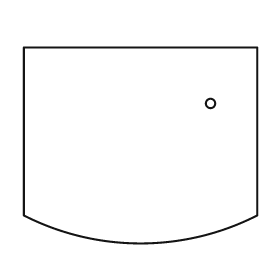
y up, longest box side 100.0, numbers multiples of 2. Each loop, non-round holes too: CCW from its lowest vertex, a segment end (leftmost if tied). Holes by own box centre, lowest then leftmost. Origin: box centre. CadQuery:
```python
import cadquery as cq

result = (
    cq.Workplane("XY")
    .moveTo(-50.0, -30.0)
    .threePointArc((0.0, -42.0), (50.0, -30.0))
    .lineTo(50.0, 42.0)
    .lineTo(-50.0, 42.0)
    .close()
    .moveTo(30.0, 18.0)
    .circle(2.0)
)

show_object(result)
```